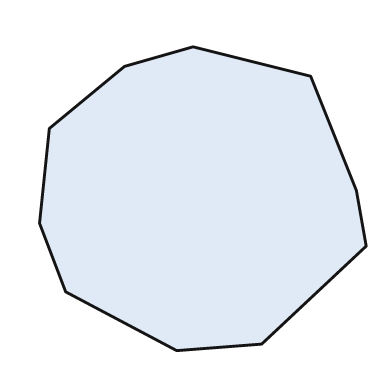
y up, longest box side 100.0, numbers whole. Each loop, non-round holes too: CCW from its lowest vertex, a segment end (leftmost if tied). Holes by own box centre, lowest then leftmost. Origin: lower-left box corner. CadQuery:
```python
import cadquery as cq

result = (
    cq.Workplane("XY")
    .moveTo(42.0, 0.0)
    .lineTo(68.0, 2.0)
    .lineTo(100.0, 32.0)
    .lineTo(97.0, 49.0)
    .lineTo(83.0, 84.0)
    .lineTo(47.0, 93.0)
    .lineTo(26.0, 87.0)
    .lineTo(3.0, 68.0)
    .lineTo(0.0, 39.0)
    .lineTo(8.0, 18.0)
    .close()
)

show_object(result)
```